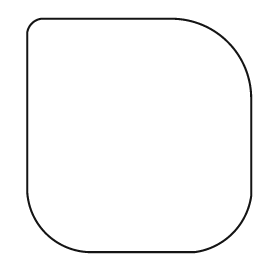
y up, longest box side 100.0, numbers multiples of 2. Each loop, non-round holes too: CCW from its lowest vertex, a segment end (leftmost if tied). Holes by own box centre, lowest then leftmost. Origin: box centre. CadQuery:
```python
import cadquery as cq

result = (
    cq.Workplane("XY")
    .moveTo(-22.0, -50.0)
    .lineTo(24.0, -50.0)
    .threePointArc((40.0, -42.0), (48.0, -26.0))
    .lineTo(48.0, 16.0)
    .threePointArc((38.0, 40.0), (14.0, 50.0))
    .lineTo(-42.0, 50.0)
    .threePointArc((-46.0, 48.0), (-48.0, 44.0))
    .lineTo(-48.0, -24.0)
    .threePointArc((-40.0, -42.0), (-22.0, -50.0))
    .close()
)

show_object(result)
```